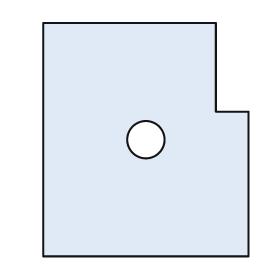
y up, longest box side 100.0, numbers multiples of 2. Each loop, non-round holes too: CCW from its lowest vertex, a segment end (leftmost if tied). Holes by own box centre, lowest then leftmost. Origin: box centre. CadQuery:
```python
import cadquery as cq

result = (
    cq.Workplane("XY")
    .moveTo(-44.0, -50.0)
    .lineTo(44.0, -50.0)
    .lineTo(44.0, 12.0)
    .lineTo(30.0, 12.0)
    .lineTo(30.0, 50.0)
    .lineTo(-44.0, 50.0)
    .close()
    .moveTo(0.0, 0.0)
    .circle(8.0)
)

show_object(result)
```